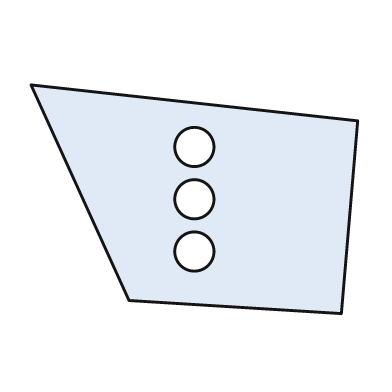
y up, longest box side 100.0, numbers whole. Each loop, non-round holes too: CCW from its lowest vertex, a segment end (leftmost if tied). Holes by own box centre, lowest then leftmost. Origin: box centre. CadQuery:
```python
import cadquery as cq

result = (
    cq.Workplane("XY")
    .moveTo(45.0, -35.0)
    .lineTo(50.0, 24.0)
    .lineTo(-50.0, 35.0)
    .lineTo(-20.0, -31.0)
    .close()
    .moveTo(0.0, -16.0)
    .circle(6.0)
    .moveTo(0.0, 0.0)
    .circle(6.0)
    .moveTo(0.0, 16.0)
    .circle(6.0)
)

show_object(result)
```